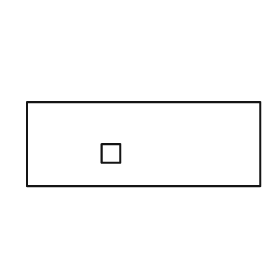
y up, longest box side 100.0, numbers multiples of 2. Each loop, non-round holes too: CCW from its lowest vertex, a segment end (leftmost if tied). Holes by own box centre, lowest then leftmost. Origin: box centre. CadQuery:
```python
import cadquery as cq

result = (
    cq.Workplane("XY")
    .moveTo(-50.0, -18.0)
    .lineTo(50.0, -18.0)
    .lineTo(50.0, 18.0)
    .lineTo(-50.0, 18.0)
    .close()
    .moveTo(-18.0, -8.0)
    .lineTo(-10.0, -8.0)
    .lineTo(-10.0, 0.0)
    .lineTo(-18.0, 0.0)
    .close()
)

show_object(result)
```